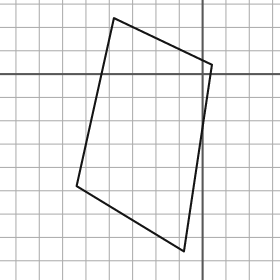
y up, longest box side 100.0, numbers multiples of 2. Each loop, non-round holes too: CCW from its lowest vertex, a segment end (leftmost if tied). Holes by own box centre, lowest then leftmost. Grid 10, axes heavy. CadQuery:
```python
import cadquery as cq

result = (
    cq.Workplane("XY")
    .moveTo(-8.0, -76.0)
    .lineTo(4.0, 4.0)
    .lineTo(-38.0, 24.0)
    .lineTo(-54.0, -48.0)
    .close()
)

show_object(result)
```